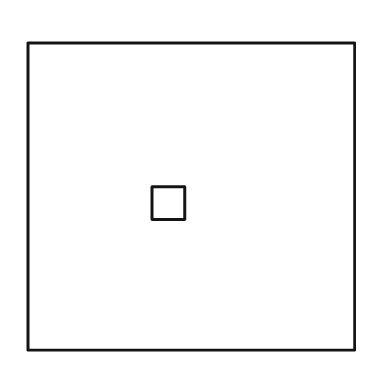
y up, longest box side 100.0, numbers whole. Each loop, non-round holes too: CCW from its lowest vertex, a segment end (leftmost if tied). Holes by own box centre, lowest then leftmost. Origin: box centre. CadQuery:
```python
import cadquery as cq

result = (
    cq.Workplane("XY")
    .moveTo(-50.0, -47.0)
    .lineTo(50.0, -47.0)
    .lineTo(50.0, 47.0)
    .lineTo(-50.0, 47.0)
    .close()
    .moveTo(-12.0, -7.0)
    .lineTo(-2.0, -7.0)
    .lineTo(-2.0, 3.0)
    .lineTo(-12.0, 3.0)
    .close()
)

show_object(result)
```